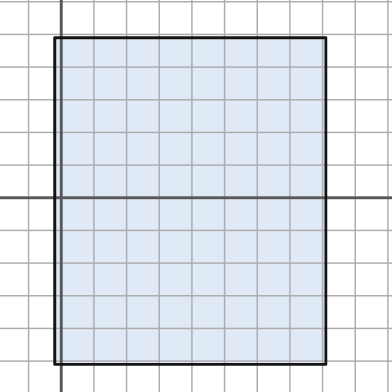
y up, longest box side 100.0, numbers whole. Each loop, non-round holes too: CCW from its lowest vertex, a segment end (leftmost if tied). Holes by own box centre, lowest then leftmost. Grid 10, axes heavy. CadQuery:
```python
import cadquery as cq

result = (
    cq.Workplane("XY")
    .moveTo(-2.0, -51.0)
    .lineTo(81.0, -51.0)
    .lineTo(81.0, 49.0)
    .lineTo(-2.0, 49.0)
    .close()
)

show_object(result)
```